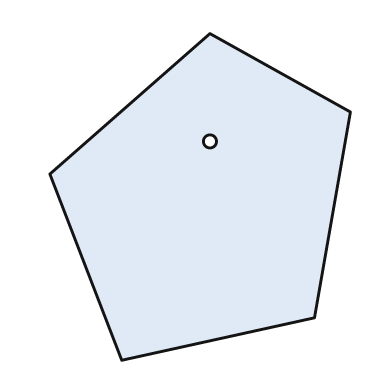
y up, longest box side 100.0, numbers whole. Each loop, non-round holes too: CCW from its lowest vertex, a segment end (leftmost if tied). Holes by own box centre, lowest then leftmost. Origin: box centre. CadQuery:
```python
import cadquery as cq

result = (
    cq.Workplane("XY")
    .moveTo(-24.0, -50.0)
    .lineTo(35.0, -37.0)
    .lineTo(46.0, 26.0)
    .lineTo(3.0, 50.0)
    .lineTo(-46.0, 7.0)
    .close()
    .moveTo(3.0, 17.0)
    .circle(2.0)
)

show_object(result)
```